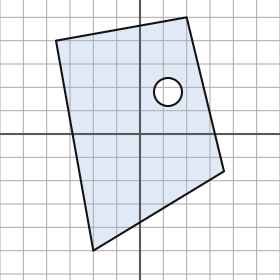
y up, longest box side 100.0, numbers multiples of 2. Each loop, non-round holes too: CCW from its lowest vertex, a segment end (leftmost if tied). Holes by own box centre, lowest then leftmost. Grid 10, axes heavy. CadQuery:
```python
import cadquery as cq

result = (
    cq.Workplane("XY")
    .moveTo(-20.0, -50.0)
    .lineTo(36.0, -16.0)
    .lineTo(20.0, 50.0)
    .lineTo(-36.0, 40.0)
    .close()
    .moveTo(12.0, 18.0)
    .circle(6.0)
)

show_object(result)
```